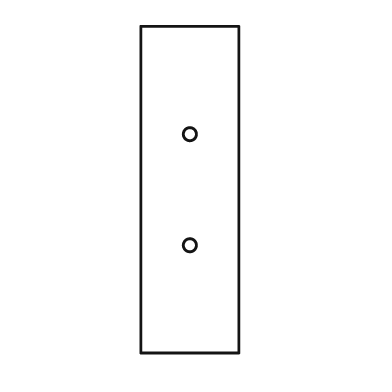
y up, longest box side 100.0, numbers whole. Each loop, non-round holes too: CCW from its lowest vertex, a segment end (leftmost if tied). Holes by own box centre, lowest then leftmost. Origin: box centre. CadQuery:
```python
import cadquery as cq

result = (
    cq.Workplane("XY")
    .moveTo(-15.0, -50.0)
    .lineTo(15.0, -50.0)
    .lineTo(15.0, 50.0)
    .lineTo(-15.0, 50.0)
    .close()
    .moveTo(0.0, -17.0)
    .circle(2.0)
    .moveTo(0.0, 17.0)
    .circle(2.0)
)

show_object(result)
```